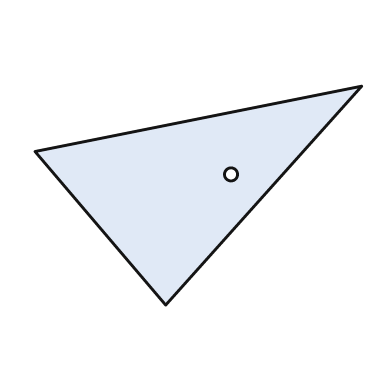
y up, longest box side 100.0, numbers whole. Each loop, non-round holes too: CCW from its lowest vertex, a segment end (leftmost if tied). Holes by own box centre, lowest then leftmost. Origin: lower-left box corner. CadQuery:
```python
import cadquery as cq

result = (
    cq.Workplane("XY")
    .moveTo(40.0, 0.0)
    .lineTo(100.0, 67.0)
    .lineTo(0.0, 47.0)
    .close()
    .moveTo(60.0, 40.0)
    .circle(2.0)
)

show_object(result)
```